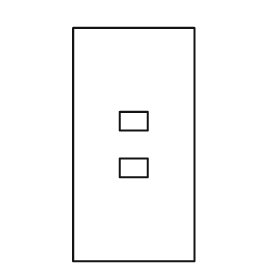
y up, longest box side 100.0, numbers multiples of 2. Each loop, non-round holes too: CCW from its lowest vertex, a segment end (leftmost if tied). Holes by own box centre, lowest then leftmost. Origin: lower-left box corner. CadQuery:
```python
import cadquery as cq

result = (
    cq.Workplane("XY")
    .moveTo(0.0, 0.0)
    .lineTo(52.0, 0.0)
    .lineTo(52.0, 100.0)
    .lineTo(0.0, 100.0)
    .close()
    .moveTo(20.0, 36.0)
    .lineTo(32.0, 36.0)
    .lineTo(32.0, 44.0)
    .lineTo(20.0, 44.0)
    .close()
    .moveTo(20.0, 56.0)
    .lineTo(32.0, 56.0)
    .lineTo(32.0, 64.0)
    .lineTo(20.0, 64.0)
    .close()
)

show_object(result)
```